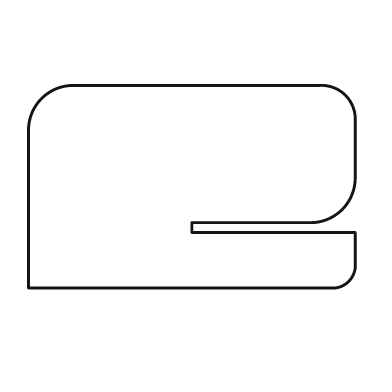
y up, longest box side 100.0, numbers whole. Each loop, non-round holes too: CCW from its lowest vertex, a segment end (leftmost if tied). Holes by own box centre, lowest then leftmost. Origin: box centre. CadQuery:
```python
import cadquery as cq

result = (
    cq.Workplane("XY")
    .moveTo(-50.0, -31.0)
    .lineTo(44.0, -31.0)
    .threePointArc((48.0, -29.0), (50.0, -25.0))
    .lineTo(50.0, -14.0)
    .lineTo(0.0, -14.0)
    .lineTo(0.0, -11.0)
    .lineTo(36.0, -11.0)
    .threePointArc((46.0, -7.0), (50.0, 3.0))
    .lineTo(50.0, 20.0)
    .threePointArc((47.0, 28.0), (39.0, 31.0))
    .lineTo(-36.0, 31.0)
    .threePointArc((-46.0, 27.0), (-50.0, 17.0))
    .close()
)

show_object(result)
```